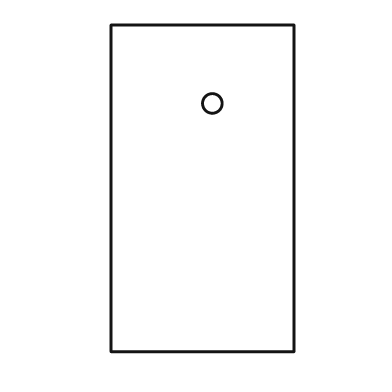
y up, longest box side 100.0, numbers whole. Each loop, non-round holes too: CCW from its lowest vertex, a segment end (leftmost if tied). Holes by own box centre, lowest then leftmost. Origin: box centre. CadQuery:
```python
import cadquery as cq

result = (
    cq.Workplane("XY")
    .moveTo(-28.0, -50.0)
    .lineTo(28.0, -50.0)
    .lineTo(28.0, 50.0)
    .lineTo(-28.0, 50.0)
    .close()
    .moveTo(3.0, 26.0)
    .circle(3.0)
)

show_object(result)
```